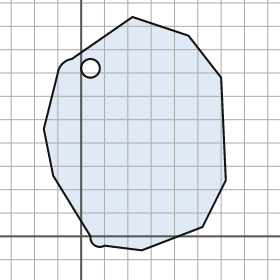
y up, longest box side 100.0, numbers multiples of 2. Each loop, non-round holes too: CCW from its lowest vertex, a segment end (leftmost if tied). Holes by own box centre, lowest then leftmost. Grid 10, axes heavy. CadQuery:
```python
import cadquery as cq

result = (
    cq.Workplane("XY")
    .moveTo(26.0, -6.0)
    .lineTo(52.0, 4.0)
    .lineTo(62.0, 24.0)
    .lineTo(60.0, 68.0)
    .lineTo(46.0, 86.0)
    .lineTo(22.0, 94.0)
    .lineTo(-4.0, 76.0)
    .threePointArc((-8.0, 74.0), (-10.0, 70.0))
    .lineTo(-16.0, 46.0)
    .lineTo(-12.0, 26.0)
    .lineTo(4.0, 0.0)
    .threePointArc((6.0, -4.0), (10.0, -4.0))
    .close()
    .moveTo(4.0, 72.0)
    .circle(4.0)
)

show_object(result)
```